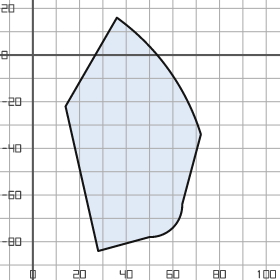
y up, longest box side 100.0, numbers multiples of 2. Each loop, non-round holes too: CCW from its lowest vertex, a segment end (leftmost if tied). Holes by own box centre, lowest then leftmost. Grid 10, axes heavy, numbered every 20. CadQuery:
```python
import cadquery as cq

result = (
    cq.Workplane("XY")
    .moveTo(28.0, -84.0)
    .lineTo(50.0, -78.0)
    .threePointArc((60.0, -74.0), (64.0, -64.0))
    .lineTo(72.0, -34.0)
    .threePointArc((58.0, -6.0), (36.0, 16.0))
    .lineTo(14.0, -22.0)
    .close()
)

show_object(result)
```